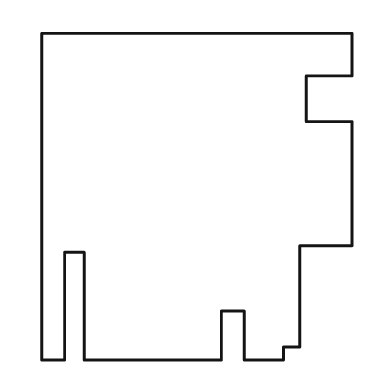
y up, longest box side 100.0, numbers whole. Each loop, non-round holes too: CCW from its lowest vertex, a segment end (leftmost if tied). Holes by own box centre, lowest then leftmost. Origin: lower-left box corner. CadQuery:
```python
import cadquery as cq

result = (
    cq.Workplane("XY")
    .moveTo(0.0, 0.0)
    .lineTo(7.0, 0.0)
    .lineTo(7.0, 33.0)
    .lineTo(13.0, 33.0)
    .lineTo(13.0, 0.0)
    .lineTo(55.0, 0.0)
    .lineTo(55.0, 15.0)
    .lineTo(62.0, 15.0)
    .lineTo(62.0, 0.0)
    .lineTo(74.0, 0.0)
    .lineTo(74.0, 4.0)
    .lineTo(79.0, 4.0)
    .lineTo(79.0, 35.0)
    .lineTo(95.0, 35.0)
    .lineTo(95.0, 73.0)
    .lineTo(81.0, 73.0)
    .lineTo(81.0, 87.0)
    .lineTo(95.0, 87.0)
    .lineTo(95.0, 100.0)
    .lineTo(0.0, 100.0)
    .close()
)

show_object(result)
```